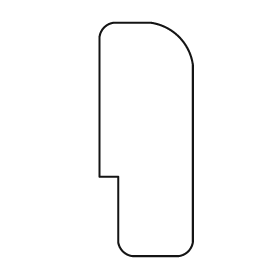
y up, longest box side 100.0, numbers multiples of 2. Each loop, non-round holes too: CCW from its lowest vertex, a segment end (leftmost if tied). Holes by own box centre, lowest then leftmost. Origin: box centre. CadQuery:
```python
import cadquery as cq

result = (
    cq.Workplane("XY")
    .moveTo(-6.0, -50.0)
    .lineTo(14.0, -50.0)
    .threePointArc((18.0, -48.0), (20.0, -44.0))
    .lineTo(20.0, 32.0)
    .threePointArc((14.0, 44.0), (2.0, 50.0))
    .lineTo(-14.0, 50.0)
    .threePointArc((-18.0, 48.0), (-20.0, 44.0))
    .lineTo(-20.0, -16.0)
    .lineTo(-12.0, -16.0)
    .lineTo(-12.0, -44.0)
    .threePointArc((-10.0, -48.0), (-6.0, -50.0))
    .close()
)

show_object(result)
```